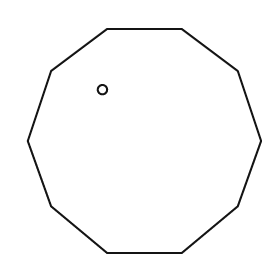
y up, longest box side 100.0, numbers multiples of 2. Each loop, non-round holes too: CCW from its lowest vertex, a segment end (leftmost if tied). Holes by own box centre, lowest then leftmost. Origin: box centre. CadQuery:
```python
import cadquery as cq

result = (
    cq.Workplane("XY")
    .moveTo(-16.0, -48.0)
    .lineTo(16.0, -48.0)
    .lineTo(40.0, -28.0)
    .lineTo(50.0, 0.0)
    .lineTo(40.0, 30.0)
    .lineTo(16.0, 48.0)
    .lineTo(-16.0, 48.0)
    .lineTo(-40.0, 30.0)
    .lineTo(-50.0, 0.0)
    .lineTo(-40.0, -28.0)
    .close()
    .moveTo(-18.0, 22.0)
    .circle(2.0)
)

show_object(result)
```